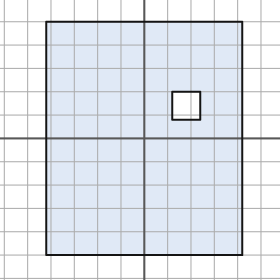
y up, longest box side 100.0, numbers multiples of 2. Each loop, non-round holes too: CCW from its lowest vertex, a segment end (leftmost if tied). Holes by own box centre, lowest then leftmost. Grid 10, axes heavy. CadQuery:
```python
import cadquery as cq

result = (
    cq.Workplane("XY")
    .moveTo(-42.0, -50.0)
    .lineTo(42.0, -50.0)
    .lineTo(42.0, 50.0)
    .lineTo(-42.0, 50.0)
    .close()
    .moveTo(12.0, 8.0)
    .lineTo(24.0, 8.0)
    .lineTo(24.0, 20.0)
    .lineTo(12.0, 20.0)
    .close()
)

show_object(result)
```